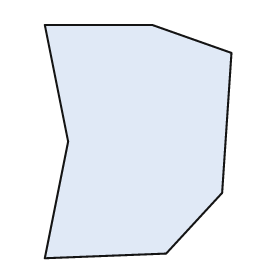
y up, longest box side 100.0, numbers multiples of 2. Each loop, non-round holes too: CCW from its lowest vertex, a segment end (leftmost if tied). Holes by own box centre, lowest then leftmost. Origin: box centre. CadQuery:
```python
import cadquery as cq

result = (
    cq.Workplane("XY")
    .moveTo(-40.0, -50.0)
    .lineTo(12.0, -48.0)
    .lineTo(36.0, -22.0)
    .lineTo(40.0, 38.0)
    .lineTo(6.0, 50.0)
    .lineTo(-40.0, 50.0)
    .lineTo(-30.0, 0.0)
    .close()
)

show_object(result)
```